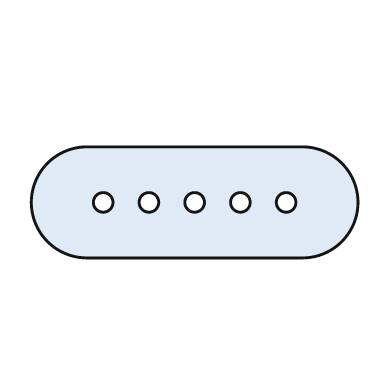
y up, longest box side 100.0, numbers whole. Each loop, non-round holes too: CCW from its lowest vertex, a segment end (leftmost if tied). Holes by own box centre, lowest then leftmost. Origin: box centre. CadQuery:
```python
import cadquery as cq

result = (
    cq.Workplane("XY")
    .moveTo(-33.0, -17.0)
    .lineTo(33.0, -17.0)
    .threePointArc((50.0, 0.0), (33.0, 17.0))
    .lineTo(-33.0, 17.0)
    .threePointArc((-50.0, 0.0), (-33.0, -17.0))
    .close()
    .moveTo(-28.0, 0.0)
    .circle(3.0)
    .moveTo(-14.0, 0.0)
    .circle(3.0)
    .moveTo(0.0, 0.0)
    .circle(3.0)
    .moveTo(14.0, 0.0)
    .circle(3.0)
    .moveTo(28.0, 0.0)
    .circle(3.0)
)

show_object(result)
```